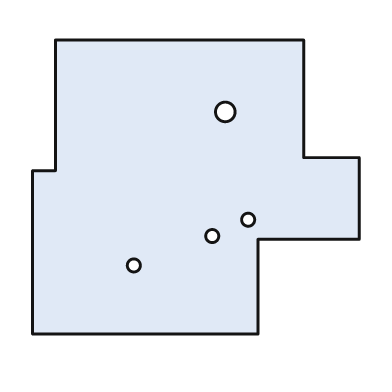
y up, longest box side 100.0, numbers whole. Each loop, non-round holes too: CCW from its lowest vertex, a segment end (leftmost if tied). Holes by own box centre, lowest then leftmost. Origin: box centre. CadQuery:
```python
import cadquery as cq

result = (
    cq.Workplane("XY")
    .moveTo(-50.0, -45.0)
    .lineTo(19.0, -45.0)
    .lineTo(19.0, -16.0)
    .lineTo(50.0, -16.0)
    .lineTo(50.0, 9.0)
    .lineTo(33.0, 9.0)
    .lineTo(33.0, 45.0)
    .lineTo(-43.0, 45.0)
    .lineTo(-43.0, 5.0)
    .lineTo(-50.0, 5.0)
    .close()
    .moveTo(-19.0, -24.0)
    .circle(2.0)
    .moveTo(5.0, -15.0)
    .circle(2.0)
    .moveTo(16.0, -10.0)
    .circle(2.0)
    .moveTo(9.0, 23.0)
    .circle(3.0)
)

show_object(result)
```